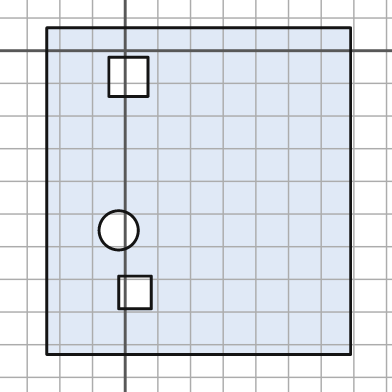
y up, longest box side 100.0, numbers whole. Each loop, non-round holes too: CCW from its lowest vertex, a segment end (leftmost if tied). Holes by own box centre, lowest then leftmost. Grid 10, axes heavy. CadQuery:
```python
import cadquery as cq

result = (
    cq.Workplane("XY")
    .moveTo(-24.0, -93.0)
    .lineTo(69.0, -93.0)
    .lineTo(69.0, 7.0)
    .lineTo(-24.0, 7.0)
    .close()
    .moveTo(-2.0, -79.0)
    .lineTo(8.0, -79.0)
    .lineTo(8.0, -69.0)
    .lineTo(-2.0, -69.0)
    .close()
    .moveTo(-2.0, -55.0)
    .circle(6.0)
    .moveTo(-5.0, -14.0)
    .lineTo(7.0, -14.0)
    .lineTo(7.0, -2.0)
    .lineTo(-5.0, -2.0)
    .close()
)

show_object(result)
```